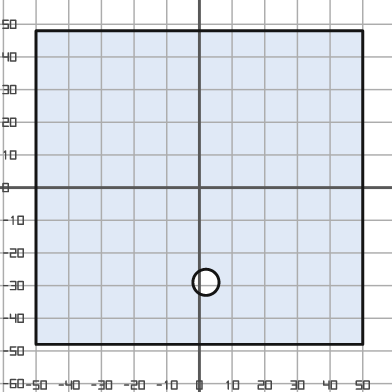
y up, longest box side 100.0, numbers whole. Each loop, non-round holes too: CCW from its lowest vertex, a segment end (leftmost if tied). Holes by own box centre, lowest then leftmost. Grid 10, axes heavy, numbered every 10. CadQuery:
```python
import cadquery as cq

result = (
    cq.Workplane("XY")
    .moveTo(-50.0, -48.0)
    .lineTo(50.0, -48.0)
    .lineTo(50.0, 48.0)
    .lineTo(-50.0, 48.0)
    .close()
    .moveTo(2.0, -29.0)
    .circle(4.0)
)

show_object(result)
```